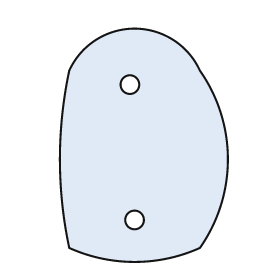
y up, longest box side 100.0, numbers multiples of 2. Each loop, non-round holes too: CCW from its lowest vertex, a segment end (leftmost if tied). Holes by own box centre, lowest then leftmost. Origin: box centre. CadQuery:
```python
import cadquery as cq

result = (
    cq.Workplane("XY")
    .moveTo(-32.0, -44.0)
    .threePointArc((-4.0, -50.0), (24.0, -44.0))
    .threePointArc((36.0, -6.0), (24.0, 32.0))
    .threePointArc((-4.0, 50.0), (-32.0, 32.0))
    .threePointArc((-36.0, -6.0), (-32.0, -44.0))
    .close()
    .moveTo(-4.0, -32.0)
    .circle(4.0)
    .moveTo(-6.0, 26.0)
    .circle(4.0)
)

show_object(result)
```